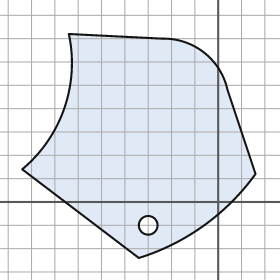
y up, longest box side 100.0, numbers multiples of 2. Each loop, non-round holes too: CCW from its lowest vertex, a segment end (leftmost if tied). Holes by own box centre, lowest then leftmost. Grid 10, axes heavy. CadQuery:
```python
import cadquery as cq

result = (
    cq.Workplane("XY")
    .moveTo(-34.0, -24.0)
    .threePointArc((-6.0, -10.0), (16.0, 12.0))
    .lineTo(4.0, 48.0)
    .threePointArc((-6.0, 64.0), (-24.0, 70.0))
    .lineTo(-64.0, 72.0)
    .threePointArc((-66.0, 40.0), (-84.0, 14.0))
    .close()
    .moveTo(-30.0, -10.0)
    .circle(4.0)
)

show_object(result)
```